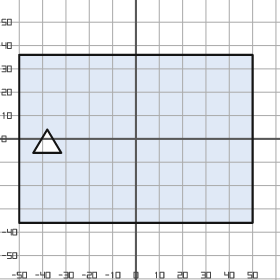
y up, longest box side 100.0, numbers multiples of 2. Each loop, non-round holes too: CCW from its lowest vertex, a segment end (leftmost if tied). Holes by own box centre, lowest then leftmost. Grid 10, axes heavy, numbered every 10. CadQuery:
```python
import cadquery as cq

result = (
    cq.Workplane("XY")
    .moveTo(-50.0, -36.0)
    .lineTo(50.0, -36.0)
    .lineTo(50.0, 36.0)
    .lineTo(-50.0, 36.0)
    .close()
    .moveTo(-44.0, -6.0)
    .lineTo(-32.0, -6.0)
    .lineTo(-38.0, 4.0)
    .close()
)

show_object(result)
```